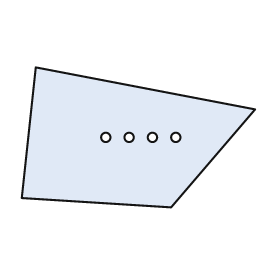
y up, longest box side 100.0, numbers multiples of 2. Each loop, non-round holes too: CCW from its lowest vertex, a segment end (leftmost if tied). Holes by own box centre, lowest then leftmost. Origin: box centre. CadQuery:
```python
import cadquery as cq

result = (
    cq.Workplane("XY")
    .moveTo(14.0, -30.0)
    .lineTo(50.0, 12.0)
    .lineTo(-44.0, 30.0)
    .lineTo(-50.0, -26.0)
    .close()
    .moveTo(-14.0, 0.0)
    .circle(2.0)
    .moveTo(-4.0, 0.0)
    .circle(2.0)
    .moveTo(6.0, 0.0)
    .circle(2.0)
    .moveTo(16.0, 0.0)
    .circle(2.0)
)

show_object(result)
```